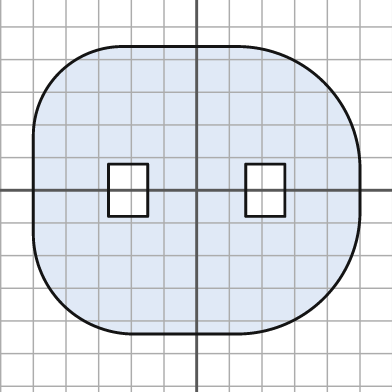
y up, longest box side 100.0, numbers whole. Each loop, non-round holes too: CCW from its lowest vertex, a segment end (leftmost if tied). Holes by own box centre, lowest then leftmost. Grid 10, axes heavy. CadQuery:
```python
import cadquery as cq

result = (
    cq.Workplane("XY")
    .moveTo(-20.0, -44.0)
    .lineTo(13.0, -44.0)
    .threePointArc((39.0, -33.0), (50.0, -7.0))
    .lineTo(50.0, 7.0)
    .threePointArc((39.0, 33.0), (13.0, 44.0))
    .lineTo(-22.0, 44.0)
    .threePointArc((-42.0, 36.0), (-50.0, 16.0))
    .lineTo(-50.0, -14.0)
    .threePointArc((-41.0, -35.0), (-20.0, -44.0))
    .close()
    .moveTo(-27.0, -8.0)
    .lineTo(-15.0, -8.0)
    .lineTo(-15.0, 8.0)
    .lineTo(-27.0, 8.0)
    .close()
    .moveTo(15.0, -8.0)
    .lineTo(27.0, -8.0)
    .lineTo(27.0, 8.0)
    .lineTo(15.0, 8.0)
    .close()
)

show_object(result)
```